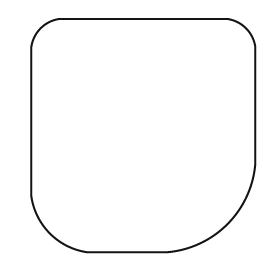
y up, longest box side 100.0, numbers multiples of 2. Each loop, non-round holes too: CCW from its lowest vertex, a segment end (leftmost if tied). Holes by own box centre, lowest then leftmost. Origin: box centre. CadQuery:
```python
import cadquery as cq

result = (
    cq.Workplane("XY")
    .moveTo(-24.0, -50.0)
    .lineTo(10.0, -50.0)
    .threePointArc((36.0, -38.0), (48.0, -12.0))
    .lineTo(48.0, 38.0)
    .threePointArc((44.0, 46.0), (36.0, 50.0))
    .lineTo(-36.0, 50.0)
    .threePointArc((-44.0, 46.0), (-48.0, 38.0))
    .lineTo(-48.0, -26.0)
    .threePointArc((-40.0, -42.0), (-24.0, -50.0))
    .close()
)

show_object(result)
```